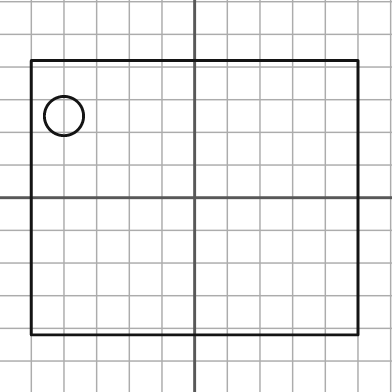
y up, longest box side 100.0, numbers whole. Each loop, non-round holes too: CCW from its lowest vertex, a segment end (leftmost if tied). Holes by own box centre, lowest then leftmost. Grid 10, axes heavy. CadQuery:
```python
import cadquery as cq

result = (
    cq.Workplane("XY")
    .moveTo(-50.0, -42.0)
    .lineTo(50.0, -42.0)
    .lineTo(50.0, 42.0)
    .lineTo(-50.0, 42.0)
    .close()
    .moveTo(-40.0, 25.0)
    .circle(6.0)
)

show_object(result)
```